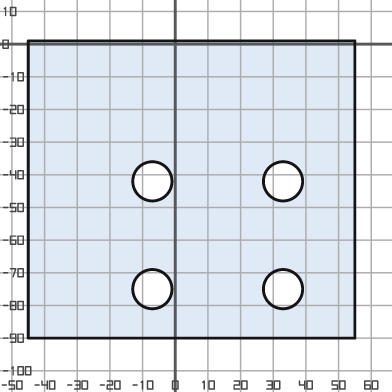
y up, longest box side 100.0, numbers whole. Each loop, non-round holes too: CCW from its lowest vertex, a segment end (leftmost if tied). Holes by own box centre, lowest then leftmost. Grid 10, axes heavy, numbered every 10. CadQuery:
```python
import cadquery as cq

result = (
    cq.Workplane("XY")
    .moveTo(-45.0, -90.0)
    .lineTo(55.0, -90.0)
    .lineTo(55.0, 1.0)
    .lineTo(-45.0, 1.0)
    .close()
    .moveTo(-7.0, -75.0)
    .circle(6.0)
    .moveTo(33.0, -75.0)
    .circle(6.0)
    .moveTo(-7.0, -42.0)
    .circle(6.0)
    .moveTo(33.0, -42.0)
    .circle(6.0)
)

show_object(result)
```